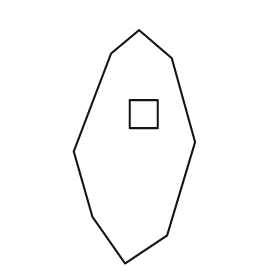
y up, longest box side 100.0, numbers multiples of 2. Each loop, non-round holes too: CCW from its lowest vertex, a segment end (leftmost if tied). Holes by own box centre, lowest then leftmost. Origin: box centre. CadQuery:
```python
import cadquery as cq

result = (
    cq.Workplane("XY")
    .moveTo(-4.0, -50.0)
    .lineTo(14.0, -38.0)
    .lineTo(26.0, 2.0)
    .lineTo(16.0, 38.0)
    .lineTo(2.0, 50.0)
    .lineTo(-10.0, 40.0)
    .lineTo(-26.0, -2.0)
    .lineTo(-18.0, -30.0)
    .close()
    .moveTo(-2.0, 8.0)
    .lineTo(10.0, 8.0)
    .lineTo(10.0, 20.0)
    .lineTo(-2.0, 20.0)
    .close()
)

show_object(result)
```